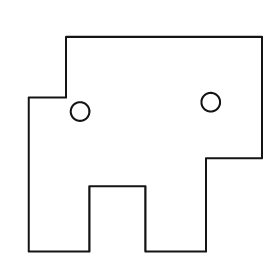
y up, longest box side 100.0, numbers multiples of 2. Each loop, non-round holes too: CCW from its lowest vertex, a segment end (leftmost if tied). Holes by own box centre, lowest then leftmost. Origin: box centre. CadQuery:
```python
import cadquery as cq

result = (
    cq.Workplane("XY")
    .moveTo(-50.0, -46.0)
    .lineTo(-24.0, -46.0)
    .lineTo(-24.0, -18.0)
    .lineTo(0.0, -18.0)
    .lineTo(0.0, -46.0)
    .lineTo(26.0, -46.0)
    .lineTo(26.0, -6.0)
    .lineTo(50.0, -6.0)
    .lineTo(50.0, 46.0)
    .lineTo(-34.0, 46.0)
    .lineTo(-34.0, 20.0)
    .lineTo(-50.0, 20.0)
    .close()
    .moveTo(-28.0, 14.0)
    .circle(4.0)
    .moveTo(28.0, 18.0)
    .circle(4.0)
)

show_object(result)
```